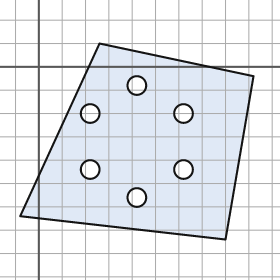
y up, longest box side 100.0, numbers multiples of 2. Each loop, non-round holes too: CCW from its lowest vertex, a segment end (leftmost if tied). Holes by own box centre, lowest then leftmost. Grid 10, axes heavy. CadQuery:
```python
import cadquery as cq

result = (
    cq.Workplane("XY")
    .moveTo(80.0, -74.0)
    .lineTo(92.0, -4.0)
    .lineTo(26.0, 10.0)
    .lineTo(-8.0, -64.0)
    .close()
    .moveTo(42.0, -56.0)
    .circle(4.0)
    .moveTo(22.0, -44.0)
    .circle(4.0)
    .moveTo(62.0, -44.0)
    .circle(4.0)
    .moveTo(22.0, -20.0)
    .circle(4.0)
    .moveTo(62.0, -20.0)
    .circle(4.0)
    .moveTo(42.0, -8.0)
    .circle(4.0)
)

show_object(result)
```